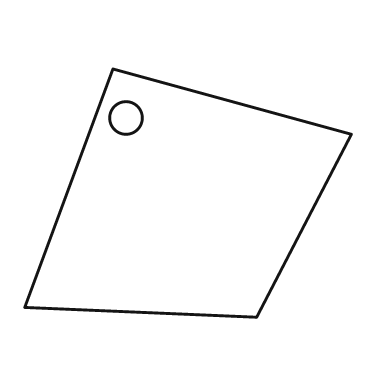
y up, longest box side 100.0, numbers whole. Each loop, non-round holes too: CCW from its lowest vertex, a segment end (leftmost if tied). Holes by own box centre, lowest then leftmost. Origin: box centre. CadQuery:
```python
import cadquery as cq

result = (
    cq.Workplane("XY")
    .moveTo(21.0, -38.0)
    .lineTo(50.0, 18.0)
    .lineTo(-23.0, 38.0)
    .lineTo(-50.0, -35.0)
    .close()
    .moveTo(-19.0, 23.0)
    .circle(5.0)
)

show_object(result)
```